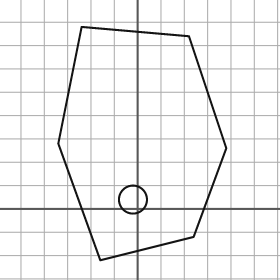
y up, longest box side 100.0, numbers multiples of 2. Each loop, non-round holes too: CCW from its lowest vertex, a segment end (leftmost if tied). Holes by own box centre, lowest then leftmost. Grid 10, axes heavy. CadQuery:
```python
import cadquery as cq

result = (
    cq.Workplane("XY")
    .moveTo(-16.0, -22.0)
    .lineTo(24.0, -12.0)
    .lineTo(38.0, 26.0)
    .lineTo(22.0, 74.0)
    .lineTo(-24.0, 78.0)
    .lineTo(-34.0, 28.0)
    .close()
    .moveTo(-2.0, 4.0)
    .circle(6.0)
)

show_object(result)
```